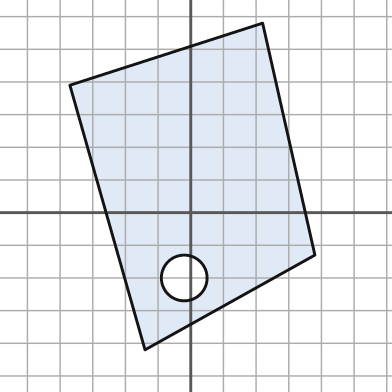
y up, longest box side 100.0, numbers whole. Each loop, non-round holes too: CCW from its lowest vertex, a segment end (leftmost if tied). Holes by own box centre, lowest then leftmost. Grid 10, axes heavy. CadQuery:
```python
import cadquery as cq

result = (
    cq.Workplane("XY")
    .moveTo(-14.0, -42.0)
    .lineTo(38.0, -13.0)
    .lineTo(22.0, 58.0)
    .lineTo(-37.0, 39.0)
    .close()
    .moveTo(-2.0, -20.0)
    .circle(7.0)
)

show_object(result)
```